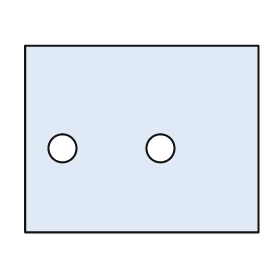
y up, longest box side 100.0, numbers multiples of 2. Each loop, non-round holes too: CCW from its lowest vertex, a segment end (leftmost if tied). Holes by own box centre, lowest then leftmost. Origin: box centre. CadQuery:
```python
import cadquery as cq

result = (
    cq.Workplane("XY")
    .moveTo(-50.0, -40.0)
    .lineTo(50.0, -40.0)
    .lineTo(50.0, 40.0)
    .lineTo(-50.0, 40.0)
    .close()
    .moveTo(-34.0, -4.0)
    .circle(6.0)
    .moveTo(8.0, -4.0)
    .circle(6.0)
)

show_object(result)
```